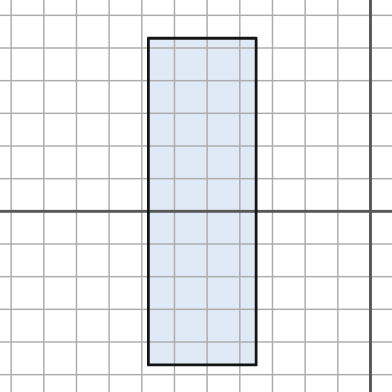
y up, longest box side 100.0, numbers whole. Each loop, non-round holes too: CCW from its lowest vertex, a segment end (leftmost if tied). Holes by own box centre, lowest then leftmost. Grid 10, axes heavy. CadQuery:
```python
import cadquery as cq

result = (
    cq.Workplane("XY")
    .moveTo(-68.0, -47.0)
    .lineTo(-35.0, -47.0)
    .lineTo(-35.0, 53.0)
    .lineTo(-68.0, 53.0)
    .close()
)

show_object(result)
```